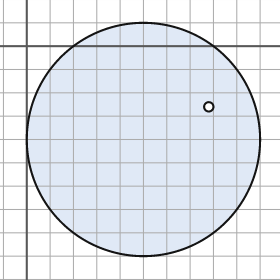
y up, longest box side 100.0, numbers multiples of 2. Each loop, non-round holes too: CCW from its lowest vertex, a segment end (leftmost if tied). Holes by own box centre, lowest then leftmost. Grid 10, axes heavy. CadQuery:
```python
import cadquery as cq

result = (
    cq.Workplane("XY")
    .moveTo(50.0, -40.0)
    .circle(50.0)
    .moveTo(78.0, -26.0)
    .circle(2.0)
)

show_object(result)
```